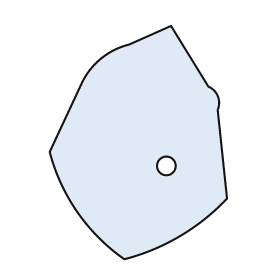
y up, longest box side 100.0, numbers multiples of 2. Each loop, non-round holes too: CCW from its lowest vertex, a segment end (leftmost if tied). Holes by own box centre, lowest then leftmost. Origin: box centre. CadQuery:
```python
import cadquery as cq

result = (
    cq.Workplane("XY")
    .moveTo(-6.0, -50.0)
    .threePointArc((18.0, -40.0), (38.0, -24.0))
    .lineTo(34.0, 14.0)
    .threePointArc((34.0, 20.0), (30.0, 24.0))
    .lineTo(14.0, 50.0)
    .lineTo(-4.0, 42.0)
    .threePointArc((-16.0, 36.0), (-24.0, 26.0))
    .lineTo(-38.0, -4.0)
    .threePointArc((-26.0, -30.0), (-6.0, -50.0))
    .close()
    .moveTo(12.0, -10.0)
    .circle(4.0)
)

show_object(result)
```